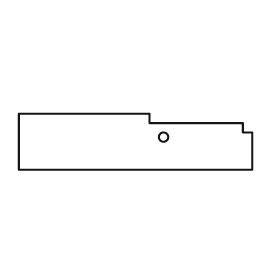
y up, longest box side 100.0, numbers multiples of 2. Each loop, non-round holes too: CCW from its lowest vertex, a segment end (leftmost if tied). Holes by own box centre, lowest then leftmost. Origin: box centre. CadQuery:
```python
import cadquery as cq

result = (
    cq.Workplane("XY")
    .moveTo(-50.0, -12.0)
    .lineTo(50.0, -12.0)
    .lineTo(50.0, 4.0)
    .lineTo(46.0, 4.0)
    .lineTo(46.0, 8.0)
    .lineTo(6.0, 8.0)
    .lineTo(6.0, 12.0)
    .lineTo(-50.0, 12.0)
    .close()
    .moveTo(12.0, 2.0)
    .circle(2.0)
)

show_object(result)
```